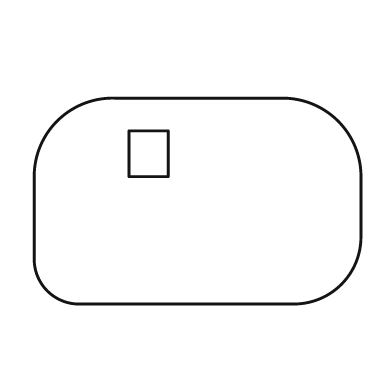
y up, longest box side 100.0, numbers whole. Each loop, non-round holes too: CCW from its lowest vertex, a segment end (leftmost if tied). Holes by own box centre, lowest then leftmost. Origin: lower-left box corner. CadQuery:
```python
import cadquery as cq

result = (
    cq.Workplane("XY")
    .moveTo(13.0, 0.0)
    .lineTo(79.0, 0.0)
    .threePointArc((94.0, 6.0), (100.0, 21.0))
    .lineTo(100.0, 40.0)
    .threePointArc((93.0, 56.0), (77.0, 63.0))
    .lineTo(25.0, 63.0)
    .threePointArc((7.0, 56.0), (0.0, 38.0))
    .lineTo(0.0, 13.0)
    .threePointArc((4.0, 4.0), (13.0, 0.0))
    .close()
    .moveTo(29.0, 39.0)
    .lineTo(41.0, 39.0)
    .lineTo(41.0, 53.0)
    .lineTo(29.0, 53.0)
    .close()
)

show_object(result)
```